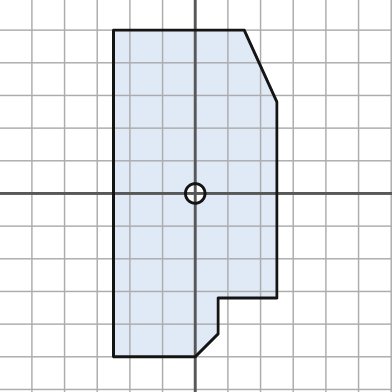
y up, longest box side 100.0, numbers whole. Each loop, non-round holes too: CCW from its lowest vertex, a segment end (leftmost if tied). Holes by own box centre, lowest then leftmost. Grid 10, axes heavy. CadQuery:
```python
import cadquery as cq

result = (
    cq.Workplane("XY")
    .moveTo(-25.0, -50.0)
    .lineTo(0.0, -50.0)
    .lineTo(7.0, -43.0)
    .lineTo(7.0, -32.0)
    .lineTo(25.0, -32.0)
    .lineTo(25.0, 28.0)
    .lineTo(15.0, 50.0)
    .lineTo(-25.0, 50.0)
    .close()
    .moveTo(0.0, 0.0)
    .circle(3.0)
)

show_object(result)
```